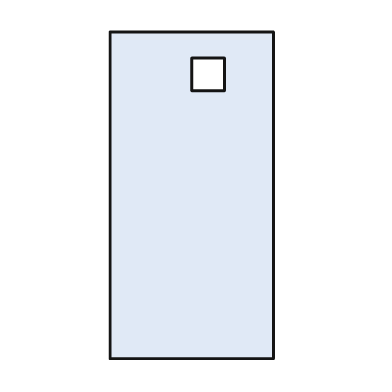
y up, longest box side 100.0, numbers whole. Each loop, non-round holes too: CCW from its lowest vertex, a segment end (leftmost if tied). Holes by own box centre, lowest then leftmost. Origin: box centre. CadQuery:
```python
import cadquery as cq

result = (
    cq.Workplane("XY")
    .moveTo(-25.0, -50.0)
    .lineTo(25.0, -50.0)
    .lineTo(25.0, 50.0)
    .lineTo(-25.0, 50.0)
    .close()
    .moveTo(0.0, 32.0)
    .lineTo(10.0, 32.0)
    .lineTo(10.0, 42.0)
    .lineTo(0.0, 42.0)
    .close()
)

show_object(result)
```